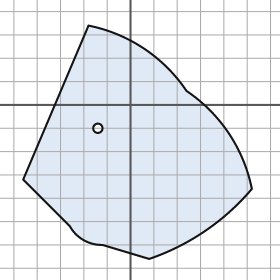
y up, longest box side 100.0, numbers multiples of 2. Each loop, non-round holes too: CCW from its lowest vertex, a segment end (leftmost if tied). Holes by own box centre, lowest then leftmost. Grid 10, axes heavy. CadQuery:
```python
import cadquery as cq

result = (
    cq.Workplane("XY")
    .moveTo(8.0, -66.0)
    .threePointArc((32.0, -54.0), (52.0, -36.0))
    .threePointArc((42.0, -12.0), (24.0, 6.0))
    .threePointArc((6.0, 24.0), (-18.0, 34.0))
    .lineTo(-46.0, -32.0)
    .lineTo(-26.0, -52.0)
    .threePointArc((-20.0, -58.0), (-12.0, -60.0))
    .close()
    .moveTo(-14.0, -10.0)
    .circle(2.0)
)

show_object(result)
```